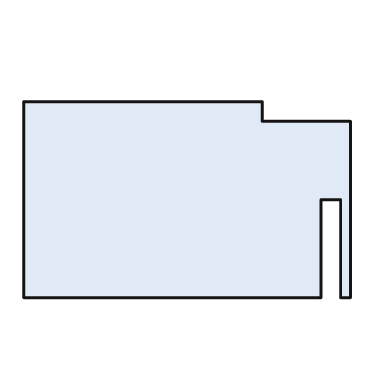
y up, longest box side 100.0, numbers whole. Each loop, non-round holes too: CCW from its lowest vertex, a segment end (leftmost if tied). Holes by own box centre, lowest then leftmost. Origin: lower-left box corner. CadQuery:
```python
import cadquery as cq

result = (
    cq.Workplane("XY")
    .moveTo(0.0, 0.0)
    .lineTo(91.0, 0.0)
    .lineTo(91.0, 30.0)
    .lineTo(97.0, 30.0)
    .lineTo(97.0, 0.0)
    .lineTo(100.0, 0.0)
    .lineTo(100.0, 54.0)
    .lineTo(73.0, 54.0)
    .lineTo(73.0, 60.0)
    .lineTo(0.0, 60.0)
    .close()
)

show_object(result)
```